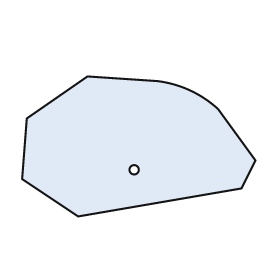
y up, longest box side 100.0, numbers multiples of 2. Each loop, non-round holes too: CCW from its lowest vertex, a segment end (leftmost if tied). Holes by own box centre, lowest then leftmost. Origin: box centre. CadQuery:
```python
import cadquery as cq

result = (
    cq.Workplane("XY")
    .moveTo(-26.0, -30.0)
    .lineTo(44.0, -18.0)
    .lineTo(50.0, -6.0)
    .lineTo(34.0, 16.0)
    .threePointArc((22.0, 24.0), (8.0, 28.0))
    .lineTo(-22.0, 30.0)
    .lineTo(-48.0, 12.0)
    .lineTo(-50.0, -14.0)
    .close()
    .moveTo(-2.0, -10.0)
    .circle(2.0)
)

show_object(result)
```